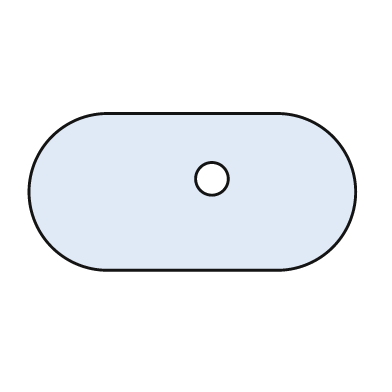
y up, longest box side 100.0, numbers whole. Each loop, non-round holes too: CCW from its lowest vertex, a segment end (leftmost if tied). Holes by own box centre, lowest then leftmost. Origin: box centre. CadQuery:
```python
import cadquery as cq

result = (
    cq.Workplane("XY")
    .moveTo(-26.0, -24.0)
    .lineTo(26.0, -24.0)
    .threePointArc((50.0, 0.0), (26.0, 24.0))
    .lineTo(-26.0, 24.0)
    .threePointArc((-50.0, 0.0), (-26.0, -24.0))
    .close()
    .moveTo(6.0, 4.0)
    .circle(5.0)
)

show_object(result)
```